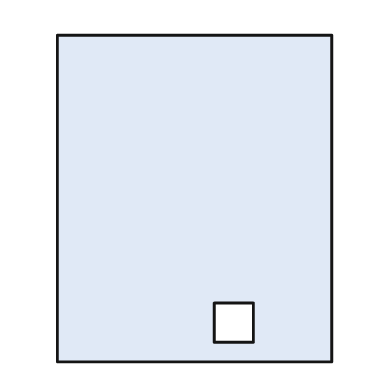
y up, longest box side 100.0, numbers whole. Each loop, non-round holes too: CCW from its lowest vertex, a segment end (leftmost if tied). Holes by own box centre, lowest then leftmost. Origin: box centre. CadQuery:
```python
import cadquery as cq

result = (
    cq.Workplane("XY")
    .moveTo(-42.0, -50.0)
    .lineTo(42.0, -50.0)
    .lineTo(42.0, 50.0)
    .lineTo(-42.0, 50.0)
    .close()
    .moveTo(6.0, -44.0)
    .lineTo(18.0, -44.0)
    .lineTo(18.0, -32.0)
    .lineTo(6.0, -32.0)
    .close()
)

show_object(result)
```